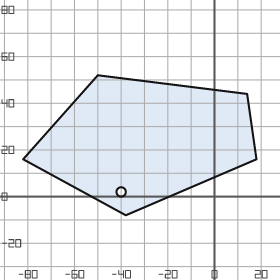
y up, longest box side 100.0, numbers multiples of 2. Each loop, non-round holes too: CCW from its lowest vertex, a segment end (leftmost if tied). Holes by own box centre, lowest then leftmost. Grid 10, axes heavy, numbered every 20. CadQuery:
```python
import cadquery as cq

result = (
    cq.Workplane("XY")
    .moveTo(-38.0, -8.0)
    .lineTo(18.0, 16.0)
    .lineTo(14.0, 44.0)
    .lineTo(-50.0, 52.0)
    .lineTo(-82.0, 16.0)
    .close()
    .moveTo(-40.0, 2.0)
    .circle(2.0)
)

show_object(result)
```